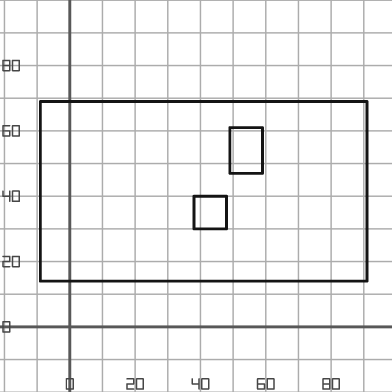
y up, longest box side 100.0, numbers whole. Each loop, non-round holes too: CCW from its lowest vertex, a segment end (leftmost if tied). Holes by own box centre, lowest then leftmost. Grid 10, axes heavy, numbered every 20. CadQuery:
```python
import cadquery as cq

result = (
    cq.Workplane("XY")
    .moveTo(-9.0, 14.0)
    .lineTo(91.0, 14.0)
    .lineTo(91.0, 69.0)
    .lineTo(-9.0, 69.0)
    .close()
    .moveTo(38.0, 30.0)
    .lineTo(48.0, 30.0)
    .lineTo(48.0, 40.0)
    .lineTo(38.0, 40.0)
    .close()
    .moveTo(49.0, 47.0)
    .lineTo(59.0, 47.0)
    .lineTo(59.0, 61.0)
    .lineTo(49.0, 61.0)
    .close()
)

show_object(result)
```